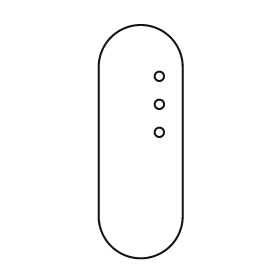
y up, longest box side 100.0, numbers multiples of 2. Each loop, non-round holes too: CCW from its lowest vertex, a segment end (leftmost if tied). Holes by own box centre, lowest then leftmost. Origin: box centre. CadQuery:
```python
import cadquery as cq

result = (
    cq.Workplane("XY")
    .moveTo(-18.0, -32.0)
    .threePointArc((0.0, -50.0), (18.0, -32.0))
    .lineTo(18.0, 32.0)
    .threePointArc((0.0, 50.0), (-18.0, 32.0))
    .close()
    .moveTo(8.0, 4.0)
    .circle(2.0)
    .moveTo(8.0, 16.0)
    .circle(2.0)
    .moveTo(8.0, 28.0)
    .circle(2.0)
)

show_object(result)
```